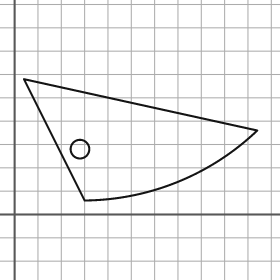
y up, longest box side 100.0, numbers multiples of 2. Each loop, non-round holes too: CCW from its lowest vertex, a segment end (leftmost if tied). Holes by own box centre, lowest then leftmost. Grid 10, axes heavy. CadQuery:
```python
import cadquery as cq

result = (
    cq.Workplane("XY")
    .moveTo(30.0, 6.0)
    .threePointArc((70.0, 14.0), (104.0, 36.0))
    .lineTo(4.0, 58.0)
    .close()
    .moveTo(28.0, 28.0)
    .circle(4.0)
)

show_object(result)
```